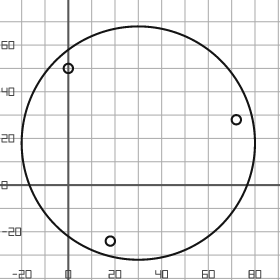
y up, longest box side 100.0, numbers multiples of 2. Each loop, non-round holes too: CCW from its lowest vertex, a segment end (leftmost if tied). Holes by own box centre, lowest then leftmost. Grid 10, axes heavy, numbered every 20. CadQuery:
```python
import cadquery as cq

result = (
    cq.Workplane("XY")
    .moveTo(30.0, 18.0)
    .circle(50.0)
    .moveTo(18.0, -24.0)
    .circle(2.0)
    .moveTo(72.0, 28.0)
    .circle(2.0)
    .moveTo(0.0, 50.0)
    .circle(2.0)
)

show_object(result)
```